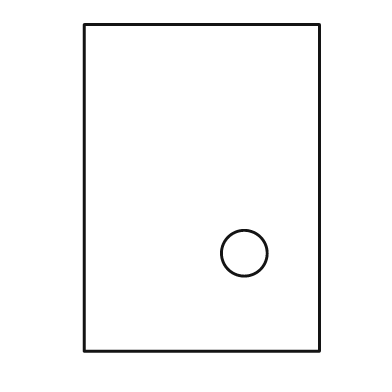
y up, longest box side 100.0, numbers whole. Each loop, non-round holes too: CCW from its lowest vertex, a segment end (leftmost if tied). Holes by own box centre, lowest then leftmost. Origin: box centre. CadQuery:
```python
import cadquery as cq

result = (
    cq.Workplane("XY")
    .moveTo(-36.0, -50.0)
    .lineTo(36.0, -50.0)
    .lineTo(36.0, 50.0)
    .lineTo(-36.0, 50.0)
    .close()
    .moveTo(13.0, -20.0)
    .circle(7.0)
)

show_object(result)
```